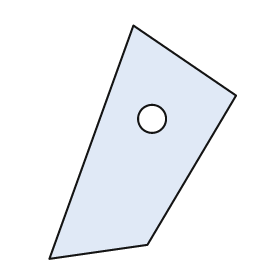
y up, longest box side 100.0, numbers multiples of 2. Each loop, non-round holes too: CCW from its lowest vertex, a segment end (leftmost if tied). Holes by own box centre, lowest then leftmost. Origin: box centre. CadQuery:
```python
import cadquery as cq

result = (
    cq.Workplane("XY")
    .moveTo(-40.0, -50.0)
    .lineTo(2.0, -44.0)
    .lineTo(40.0, 20.0)
    .lineTo(-4.0, 50.0)
    .close()
    .moveTo(4.0, 10.0)
    .circle(6.0)
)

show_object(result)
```